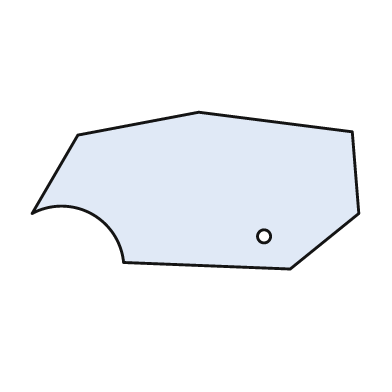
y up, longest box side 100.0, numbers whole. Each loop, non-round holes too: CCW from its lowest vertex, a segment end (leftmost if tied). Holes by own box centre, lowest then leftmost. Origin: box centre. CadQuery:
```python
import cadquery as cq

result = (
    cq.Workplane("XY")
    .moveTo(29.0, -24.0)
    .lineTo(50.0, -7.0)
    .lineTo(48.0, 18.0)
    .lineTo(1.0, 24.0)
    .lineTo(-36.0, 17.0)
    .lineTo(-50.0, -7.0)
    .threePointArc((-32.0, -7.0), (-22.0, -22.0))
    .close()
    .moveTo(21.0, -14.0)
    .circle(2.0)
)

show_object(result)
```